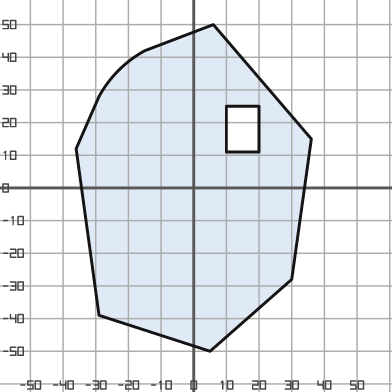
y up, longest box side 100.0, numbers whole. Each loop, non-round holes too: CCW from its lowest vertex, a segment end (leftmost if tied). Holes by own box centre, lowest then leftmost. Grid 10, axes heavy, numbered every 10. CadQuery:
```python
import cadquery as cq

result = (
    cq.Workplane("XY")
    .moveTo(5.0, -50.0)
    .lineTo(30.0, -28.0)
    .lineTo(36.0, 15.0)
    .lineTo(6.0, 50.0)
    .lineTo(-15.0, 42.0)
    .threePointArc((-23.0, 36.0), (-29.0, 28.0))
    .lineTo(-36.0, 12.0)
    .lineTo(-29.0, -39.0)
    .close()
    .moveTo(10.0, 11.0)
    .lineTo(20.0, 11.0)
    .lineTo(20.0, 25.0)
    .lineTo(10.0, 25.0)
    .close()
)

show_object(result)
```